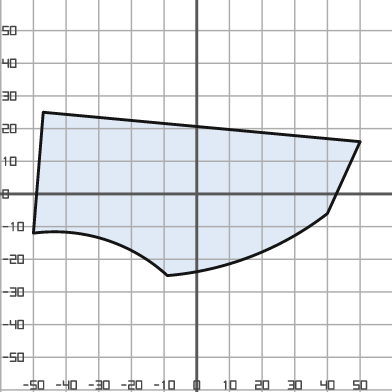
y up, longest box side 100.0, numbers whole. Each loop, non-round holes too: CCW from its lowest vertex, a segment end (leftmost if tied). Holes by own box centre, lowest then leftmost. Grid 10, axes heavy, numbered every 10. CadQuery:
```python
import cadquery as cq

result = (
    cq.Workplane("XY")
    .moveTo(-9.0, -25.0)
    .threePointArc((17.0, -19.0), (40.0, -6.0))
    .lineTo(50.0, 16.0)
    .lineTo(-47.0, 25.0)
    .lineTo(-50.0, -12.0)
    .threePointArc((-28.0, -14.0), (-9.0, -25.0))
    .close()
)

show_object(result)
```